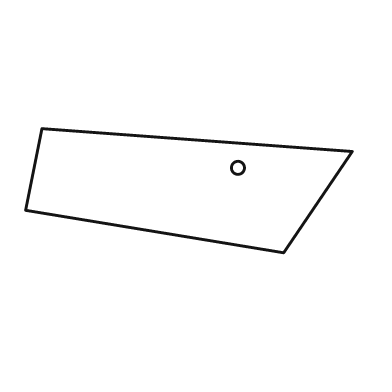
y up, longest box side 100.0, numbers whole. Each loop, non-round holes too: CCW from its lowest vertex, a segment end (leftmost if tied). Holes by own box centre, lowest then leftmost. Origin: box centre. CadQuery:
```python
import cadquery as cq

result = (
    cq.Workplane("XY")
    .moveTo(29.0, -19.0)
    .lineTo(50.0, 12.0)
    .lineTo(-45.0, 19.0)
    .lineTo(-50.0, -6.0)
    .close()
    .moveTo(15.0, 7.0)
    .circle(2.0)
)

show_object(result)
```